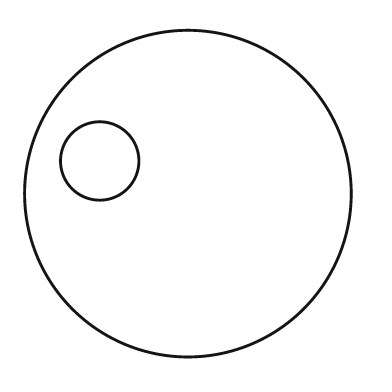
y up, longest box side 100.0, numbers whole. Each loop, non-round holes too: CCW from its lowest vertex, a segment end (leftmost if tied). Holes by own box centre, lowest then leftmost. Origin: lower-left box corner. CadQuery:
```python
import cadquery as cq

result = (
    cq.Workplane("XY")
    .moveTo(50.0, 50.0)
    .circle(50.0)
    .moveTo(23.0, 60.0)
    .circle(12.0)
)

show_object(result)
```